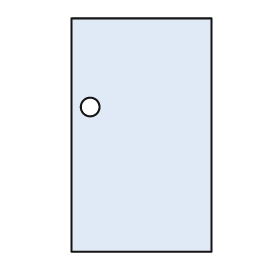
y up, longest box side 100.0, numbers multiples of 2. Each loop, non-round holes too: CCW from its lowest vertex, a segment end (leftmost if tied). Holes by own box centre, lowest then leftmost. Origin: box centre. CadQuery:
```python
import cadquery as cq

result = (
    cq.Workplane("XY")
    .moveTo(-30.0, -50.0)
    .lineTo(30.0, -50.0)
    .lineTo(30.0, 50.0)
    .lineTo(-30.0, 50.0)
    .close()
    .moveTo(-22.0, 12.0)
    .circle(4.0)
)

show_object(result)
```